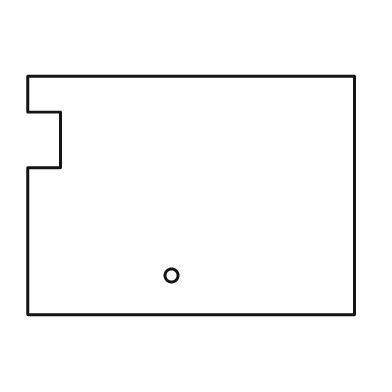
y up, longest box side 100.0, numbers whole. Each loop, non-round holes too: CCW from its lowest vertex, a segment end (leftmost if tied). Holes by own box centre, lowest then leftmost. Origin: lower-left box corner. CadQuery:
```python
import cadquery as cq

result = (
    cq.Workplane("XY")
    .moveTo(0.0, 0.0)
    .lineTo(100.0, 0.0)
    .lineTo(100.0, 73.0)
    .lineTo(0.0, 73.0)
    .lineTo(0.0, 62.0)
    .lineTo(10.0, 62.0)
    .lineTo(10.0, 45.0)
    .lineTo(0.0, 45.0)
    .close()
    .moveTo(44.0, 12.0)
    .circle(2.0)
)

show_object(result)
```